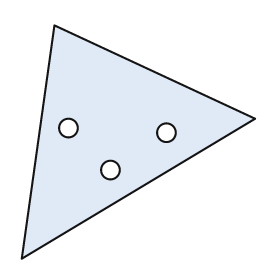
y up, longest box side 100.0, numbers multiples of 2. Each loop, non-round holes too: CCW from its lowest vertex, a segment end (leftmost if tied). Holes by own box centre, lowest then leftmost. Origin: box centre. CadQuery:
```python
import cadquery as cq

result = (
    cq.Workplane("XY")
    .moveTo(-50.0, -50.0)
    .lineTo(50.0, 10.0)
    .lineTo(-36.0, 50.0)
    .close()
    .moveTo(-12.0, -12.0)
    .circle(4.0)
    .moveTo(12.0, 4.0)
    .circle(4.0)
    .moveTo(-30.0, 6.0)
    .circle(4.0)
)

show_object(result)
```